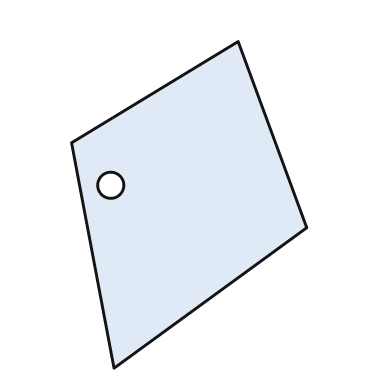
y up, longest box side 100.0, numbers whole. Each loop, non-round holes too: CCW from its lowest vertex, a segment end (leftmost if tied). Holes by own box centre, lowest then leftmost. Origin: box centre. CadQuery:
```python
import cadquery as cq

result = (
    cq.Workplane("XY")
    .moveTo(-23.0, -50.0)
    .lineTo(36.0, -7.0)
    .lineTo(15.0, 50.0)
    .lineTo(-36.0, 19.0)
    .close()
    .moveTo(-24.0, 6.0)
    .circle(4.0)
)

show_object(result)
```